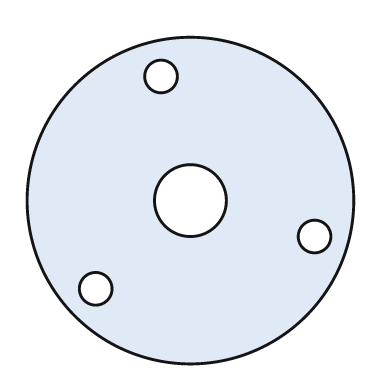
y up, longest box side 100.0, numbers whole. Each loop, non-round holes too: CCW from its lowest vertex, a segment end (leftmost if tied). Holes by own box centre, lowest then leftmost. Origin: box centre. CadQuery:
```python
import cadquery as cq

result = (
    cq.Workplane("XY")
    .moveTo(0.0, 0.0)
    .circle(50.0)
    .moveTo(-29.0, -27.0)
    .circle(5.0)
    .moveTo(38.0, -11.0)
    .circle(5.0)
    .moveTo(0.0, 0.0)
    .circle(11.0)
    .moveTo(-9.0, 38.0)
    .circle(5.0)
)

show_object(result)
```